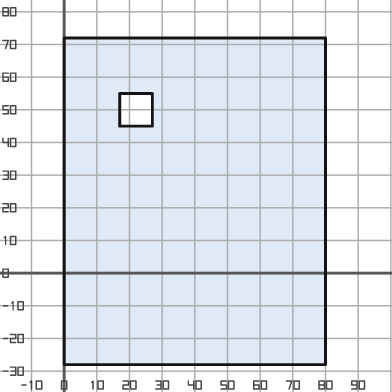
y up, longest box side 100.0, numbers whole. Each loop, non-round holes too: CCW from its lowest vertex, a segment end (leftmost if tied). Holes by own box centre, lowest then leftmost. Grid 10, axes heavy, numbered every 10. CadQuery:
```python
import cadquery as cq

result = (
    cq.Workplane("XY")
    .moveTo(0.0, -28.0)
    .lineTo(80.0, -28.0)
    .lineTo(80.0, 72.0)
    .lineTo(0.0, 72.0)
    .close()
    .moveTo(17.0, 45.0)
    .lineTo(27.0, 45.0)
    .lineTo(27.0, 55.0)
    .lineTo(17.0, 55.0)
    .close()
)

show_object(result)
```